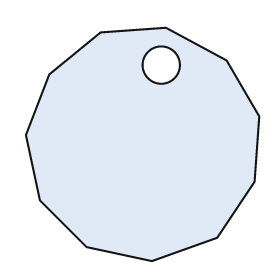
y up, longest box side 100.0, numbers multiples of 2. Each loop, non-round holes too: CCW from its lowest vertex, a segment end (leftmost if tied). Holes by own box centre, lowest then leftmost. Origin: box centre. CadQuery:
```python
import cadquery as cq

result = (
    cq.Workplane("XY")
    .moveTo(4.0, -50.0)
    .lineTo(32.0, -40.0)
    .lineTo(48.0, -16.0)
    .lineTo(50.0, 12.0)
    .lineTo(36.0, 36.0)
    .lineTo(10.0, 50.0)
    .lineTo(-18.0, 48.0)
    .lineTo(-40.0, 30.0)
    .lineTo(-50.0, 4.0)
    .lineTo(-44.0, -24.0)
    .lineTo(-24.0, -44.0)
    .close()
    .moveTo(8.0, 34.0)
    .circle(8.0)
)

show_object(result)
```